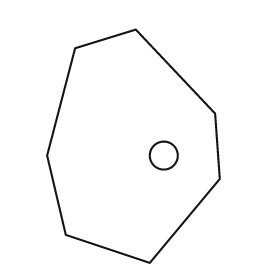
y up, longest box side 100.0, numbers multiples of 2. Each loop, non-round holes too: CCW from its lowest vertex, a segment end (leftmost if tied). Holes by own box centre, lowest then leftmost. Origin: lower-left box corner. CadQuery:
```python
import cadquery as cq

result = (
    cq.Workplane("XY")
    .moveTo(44.0, 0.0)
    .lineTo(74.0, 36.0)
    .lineTo(72.0, 64.0)
    .lineTo(38.0, 100.0)
    .lineTo(12.0, 92.0)
    .lineTo(0.0, 46.0)
    .lineTo(8.0, 12.0)
    .close()
    .moveTo(50.0, 46.0)
    .circle(6.0)
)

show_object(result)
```